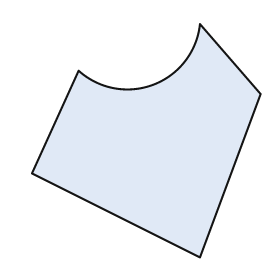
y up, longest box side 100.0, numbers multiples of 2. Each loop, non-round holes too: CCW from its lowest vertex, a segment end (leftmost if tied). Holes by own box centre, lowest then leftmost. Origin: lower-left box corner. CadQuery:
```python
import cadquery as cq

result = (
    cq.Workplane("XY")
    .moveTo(72.0, 0.0)
    .lineTo(98.0, 70.0)
    .lineTo(72.0, 100.0)
    .threePointArc((52.0, 74.0), (20.0, 80.0))
    .lineTo(0.0, 36.0)
    .close()
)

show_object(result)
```